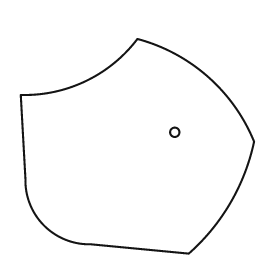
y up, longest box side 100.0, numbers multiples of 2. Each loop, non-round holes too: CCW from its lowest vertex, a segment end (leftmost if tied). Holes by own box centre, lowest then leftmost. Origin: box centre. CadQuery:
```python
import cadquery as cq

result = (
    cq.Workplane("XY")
    .moveTo(22.0, -46.0)
    .threePointArc((40.0, -24.0), (50.0, 2.0))
    .threePointArc((30.0, 30.0), (0.0, 46.0))
    .threePointArc((-22.0, 28.0), (-50.0, 22.0))
    .lineTo(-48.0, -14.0)
    .threePointArc((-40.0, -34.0), (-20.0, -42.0))
    .close()
    .moveTo(16.0, 6.0)
    .circle(2.0)
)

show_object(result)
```